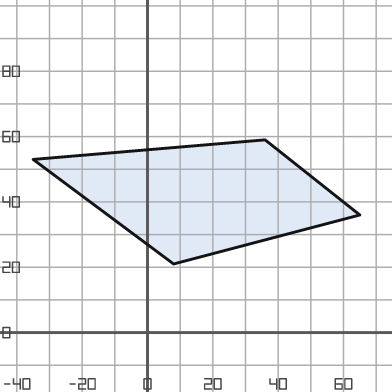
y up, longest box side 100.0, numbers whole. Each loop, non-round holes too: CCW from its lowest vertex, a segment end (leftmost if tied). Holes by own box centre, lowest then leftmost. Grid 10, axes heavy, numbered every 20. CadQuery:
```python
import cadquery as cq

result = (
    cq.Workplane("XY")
    .moveTo(8.0, 21.0)
    .lineTo(65.0, 36.0)
    .lineTo(36.0, 59.0)
    .lineTo(-35.0, 53.0)
    .close()
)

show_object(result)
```